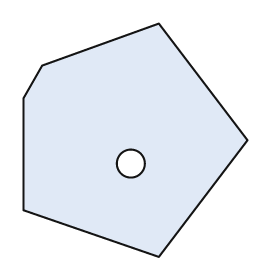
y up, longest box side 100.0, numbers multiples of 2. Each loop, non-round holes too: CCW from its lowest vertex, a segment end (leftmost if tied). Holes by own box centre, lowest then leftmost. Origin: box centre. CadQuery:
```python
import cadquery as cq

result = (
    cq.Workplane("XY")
    .moveTo(10.0, -50.0)
    .lineTo(48.0, 0.0)
    .lineTo(10.0, 50.0)
    .lineTo(-40.0, 32.0)
    .lineTo(-48.0, 18.0)
    .lineTo(-48.0, -30.0)
    .close()
    .moveTo(-2.0, -10.0)
    .circle(6.0)
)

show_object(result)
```